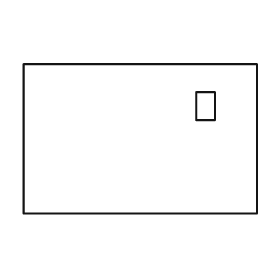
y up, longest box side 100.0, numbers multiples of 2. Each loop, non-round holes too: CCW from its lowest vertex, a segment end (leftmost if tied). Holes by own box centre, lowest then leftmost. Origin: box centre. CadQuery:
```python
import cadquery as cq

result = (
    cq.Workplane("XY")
    .moveTo(-50.0, -32.0)
    .lineTo(50.0, -32.0)
    .lineTo(50.0, 32.0)
    .lineTo(-50.0, 32.0)
    .close()
    .moveTo(24.0, 8.0)
    .lineTo(32.0, 8.0)
    .lineTo(32.0, 20.0)
    .lineTo(24.0, 20.0)
    .close()
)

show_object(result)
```